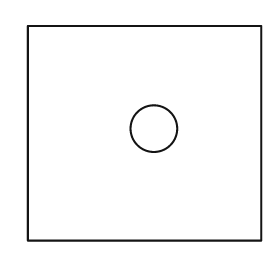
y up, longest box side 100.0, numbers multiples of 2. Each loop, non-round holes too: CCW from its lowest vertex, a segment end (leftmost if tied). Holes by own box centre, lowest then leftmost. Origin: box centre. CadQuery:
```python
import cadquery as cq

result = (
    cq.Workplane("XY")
    .moveTo(-50.0, -46.0)
    .lineTo(50.0, -46.0)
    .lineTo(50.0, 46.0)
    .lineTo(-50.0, 46.0)
    .close()
    .moveTo(4.0, 2.0)
    .circle(10.0)
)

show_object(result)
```